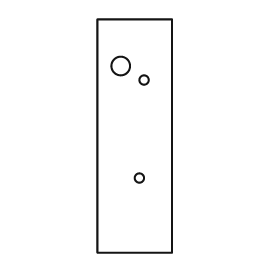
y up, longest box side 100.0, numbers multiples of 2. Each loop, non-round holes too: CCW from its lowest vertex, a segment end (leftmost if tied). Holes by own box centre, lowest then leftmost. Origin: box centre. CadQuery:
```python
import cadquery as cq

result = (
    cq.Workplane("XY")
    .moveTo(-16.0, -50.0)
    .lineTo(16.0, -50.0)
    .lineTo(16.0, 50.0)
    .lineTo(-16.0, 50.0)
    .close()
    .moveTo(2.0, -18.0)
    .circle(2.0)
    .moveTo(4.0, 24.0)
    .circle(2.0)
    .moveTo(-6.0, 30.0)
    .circle(4.0)
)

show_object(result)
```